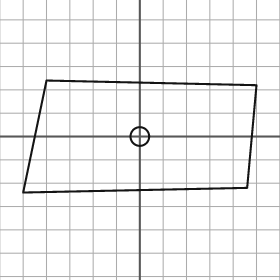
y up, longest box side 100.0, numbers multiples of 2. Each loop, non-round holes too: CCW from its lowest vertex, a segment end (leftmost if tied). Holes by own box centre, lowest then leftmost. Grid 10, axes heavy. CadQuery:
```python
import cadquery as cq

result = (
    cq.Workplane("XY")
    .moveTo(-50.0, -24.0)
    .lineTo(46.0, -22.0)
    .lineTo(50.0, 22.0)
    .lineTo(-40.0, 24.0)
    .close()
    .moveTo(0.0, 0.0)
    .circle(4.0)
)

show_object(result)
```